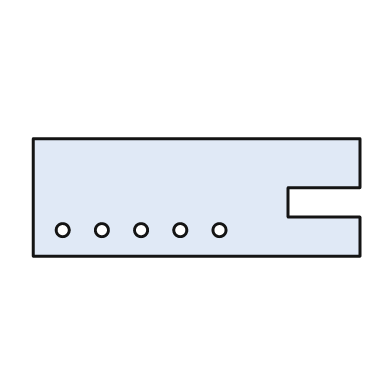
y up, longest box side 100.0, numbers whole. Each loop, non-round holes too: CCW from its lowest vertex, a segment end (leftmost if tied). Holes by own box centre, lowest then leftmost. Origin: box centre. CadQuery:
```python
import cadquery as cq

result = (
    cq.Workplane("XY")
    .moveTo(-50.0, -18.0)
    .lineTo(50.0, -18.0)
    .lineTo(50.0, -6.0)
    .lineTo(28.0, -6.0)
    .lineTo(28.0, 3.0)
    .lineTo(50.0, 3.0)
    .lineTo(50.0, 18.0)
    .lineTo(-50.0, 18.0)
    .close()
    .moveTo(-41.0, -10.0)
    .circle(2.0)
    .moveTo(-29.0, -10.0)
    .circle(2.0)
    .moveTo(-17.0, -10.0)
    .circle(2.0)
    .moveTo(-5.0, -10.0)
    .circle(2.0)
    .moveTo(7.0, -10.0)
    .circle(2.0)
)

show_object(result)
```